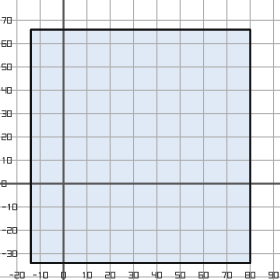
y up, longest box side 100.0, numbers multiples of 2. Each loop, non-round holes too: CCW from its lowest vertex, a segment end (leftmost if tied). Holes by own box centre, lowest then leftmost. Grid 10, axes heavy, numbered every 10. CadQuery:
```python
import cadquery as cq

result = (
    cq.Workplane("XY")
    .moveTo(-14.0, -34.0)
    .lineTo(80.0, -34.0)
    .lineTo(80.0, 66.0)
    .lineTo(-14.0, 66.0)
    .close()
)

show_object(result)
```